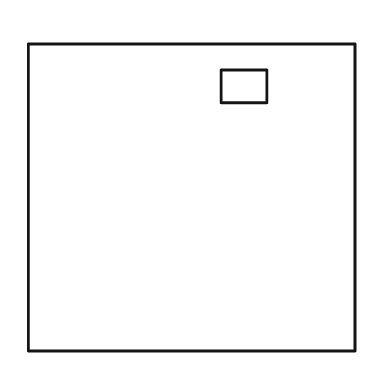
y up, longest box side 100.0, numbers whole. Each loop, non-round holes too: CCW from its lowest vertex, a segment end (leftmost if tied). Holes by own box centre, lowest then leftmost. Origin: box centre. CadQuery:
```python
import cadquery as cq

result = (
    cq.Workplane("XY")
    .moveTo(-50.0, -47.0)
    .lineTo(50.0, -47.0)
    .lineTo(50.0, 47.0)
    .lineTo(-50.0, 47.0)
    .close()
    .moveTo(9.0, 29.0)
    .lineTo(23.0, 29.0)
    .lineTo(23.0, 39.0)
    .lineTo(9.0, 39.0)
    .close()
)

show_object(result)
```